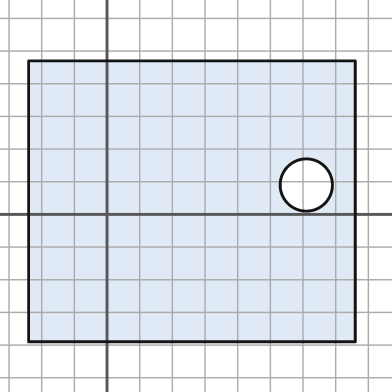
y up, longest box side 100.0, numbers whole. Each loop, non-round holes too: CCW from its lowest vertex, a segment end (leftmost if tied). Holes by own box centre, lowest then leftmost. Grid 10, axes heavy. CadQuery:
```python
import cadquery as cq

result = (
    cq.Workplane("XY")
    .moveTo(-24.0, -39.0)
    .lineTo(76.0, -39.0)
    .lineTo(76.0, 47.0)
    .lineTo(-24.0, 47.0)
    .close()
    .moveTo(61.0, 9.0)
    .circle(8.0)
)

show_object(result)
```